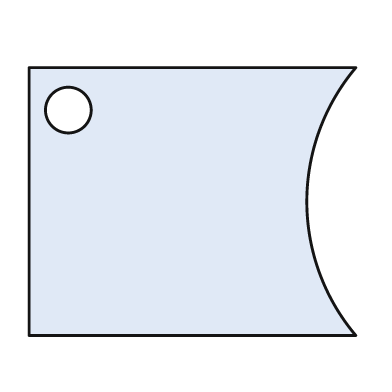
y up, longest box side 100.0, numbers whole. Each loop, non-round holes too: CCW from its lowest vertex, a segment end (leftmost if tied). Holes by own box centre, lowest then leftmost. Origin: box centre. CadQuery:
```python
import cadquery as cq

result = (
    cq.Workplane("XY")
    .moveTo(-50.0, -41.0)
    .lineTo(50.0, -41.0)
    .threePointArc((35.0, 0.0), (50.0, 41.0))
    .lineTo(-50.0, 41.0)
    .close()
    .moveTo(-38.0, 28.0)
    .circle(7.0)
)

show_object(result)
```